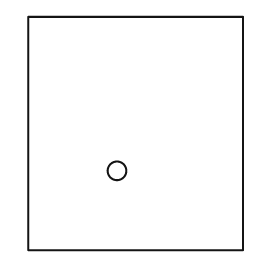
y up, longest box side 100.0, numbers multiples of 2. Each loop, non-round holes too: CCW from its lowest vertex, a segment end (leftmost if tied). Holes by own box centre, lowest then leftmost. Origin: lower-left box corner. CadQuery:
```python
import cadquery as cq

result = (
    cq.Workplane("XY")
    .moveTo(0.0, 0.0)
    .lineTo(92.0, 0.0)
    .lineTo(92.0, 100.0)
    .lineTo(0.0, 100.0)
    .close()
    .moveTo(38.0, 34.0)
    .circle(4.0)
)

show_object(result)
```